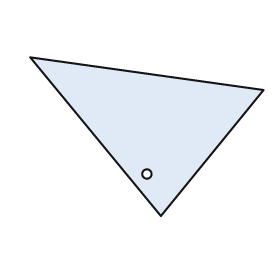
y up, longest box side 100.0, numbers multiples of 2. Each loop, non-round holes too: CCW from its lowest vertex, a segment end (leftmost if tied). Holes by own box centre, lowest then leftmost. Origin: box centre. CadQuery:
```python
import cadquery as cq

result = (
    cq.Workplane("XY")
    .moveTo(6.0, -34.0)
    .lineTo(50.0, 20.0)
    .lineTo(-50.0, 34.0)
    .close()
    .moveTo(0.0, -16.0)
    .circle(2.0)
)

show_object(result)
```